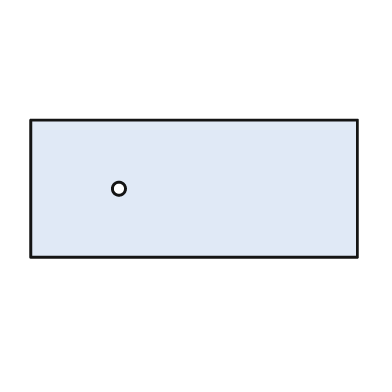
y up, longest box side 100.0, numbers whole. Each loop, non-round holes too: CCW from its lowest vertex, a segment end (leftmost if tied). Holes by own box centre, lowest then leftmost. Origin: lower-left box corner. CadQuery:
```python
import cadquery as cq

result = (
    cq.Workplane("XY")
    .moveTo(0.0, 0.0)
    .lineTo(100.0, 0.0)
    .lineTo(100.0, 42.0)
    .lineTo(0.0, 42.0)
    .close()
    .moveTo(27.0, 21.0)
    .circle(2.0)
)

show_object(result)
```